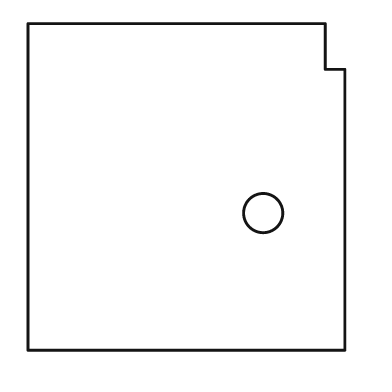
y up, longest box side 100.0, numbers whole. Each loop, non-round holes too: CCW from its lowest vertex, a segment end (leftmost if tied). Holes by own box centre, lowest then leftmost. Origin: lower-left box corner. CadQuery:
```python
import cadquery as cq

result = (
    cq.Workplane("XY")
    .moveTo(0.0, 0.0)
    .lineTo(97.0, 0.0)
    .lineTo(97.0, 86.0)
    .lineTo(91.0, 86.0)
    .lineTo(91.0, 100.0)
    .lineTo(0.0, 100.0)
    .close()
    .moveTo(72.0, 42.0)
    .circle(6.0)
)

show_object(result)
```